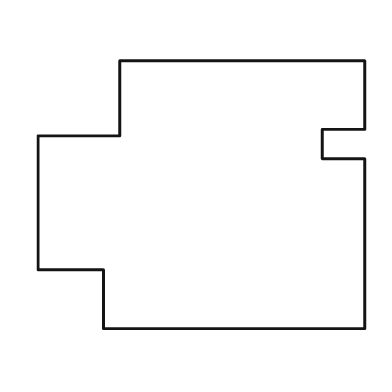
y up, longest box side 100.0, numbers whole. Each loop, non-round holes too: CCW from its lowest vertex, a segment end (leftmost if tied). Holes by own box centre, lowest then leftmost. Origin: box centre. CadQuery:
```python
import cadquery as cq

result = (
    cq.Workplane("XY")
    .moveTo(-30.0, -41.0)
    .lineTo(50.0, -41.0)
    .lineTo(50.0, 11.0)
    .lineTo(37.0, 11.0)
    .lineTo(37.0, 20.0)
    .lineTo(50.0, 20.0)
    .lineTo(50.0, 41.0)
    .lineTo(-25.0, 41.0)
    .lineTo(-25.0, 18.0)
    .lineTo(-50.0, 18.0)
    .lineTo(-50.0, -23.0)
    .lineTo(-30.0, -23.0)
    .close()
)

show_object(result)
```